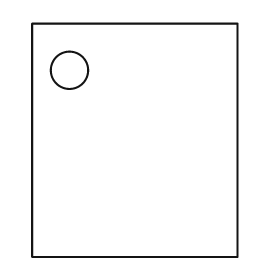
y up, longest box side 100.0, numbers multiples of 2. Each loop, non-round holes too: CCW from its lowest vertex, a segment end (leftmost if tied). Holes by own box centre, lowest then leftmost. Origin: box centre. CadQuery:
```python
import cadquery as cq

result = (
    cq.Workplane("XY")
    .moveTo(-44.0, -50.0)
    .lineTo(44.0, -50.0)
    .lineTo(44.0, 50.0)
    .lineTo(-44.0, 50.0)
    .close()
    .moveTo(-28.0, 30.0)
    .circle(8.0)
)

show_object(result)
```